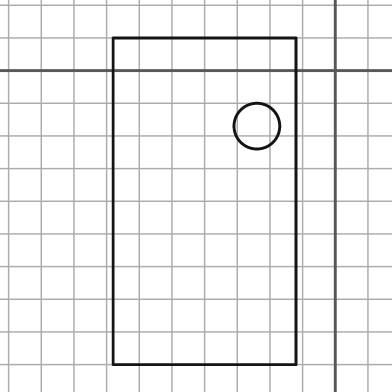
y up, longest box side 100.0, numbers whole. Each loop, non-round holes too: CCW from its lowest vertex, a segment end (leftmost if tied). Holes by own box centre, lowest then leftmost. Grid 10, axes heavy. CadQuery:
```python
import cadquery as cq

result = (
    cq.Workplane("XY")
    .moveTo(-68.0, -90.0)
    .lineTo(-12.0, -90.0)
    .lineTo(-12.0, 10.0)
    .lineTo(-68.0, 10.0)
    .close()
    .moveTo(-24.0, -17.0)
    .circle(7.0)
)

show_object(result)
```